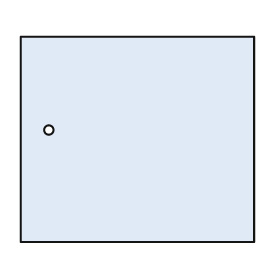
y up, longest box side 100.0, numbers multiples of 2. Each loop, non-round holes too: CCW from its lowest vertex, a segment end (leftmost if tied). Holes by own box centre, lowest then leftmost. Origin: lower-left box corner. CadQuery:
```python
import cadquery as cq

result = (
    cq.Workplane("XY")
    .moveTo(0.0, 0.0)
    .lineTo(100.0, 0.0)
    .lineTo(100.0, 88.0)
    .lineTo(0.0, 88.0)
    .close()
    .moveTo(12.0, 48.0)
    .circle(2.0)
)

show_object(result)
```